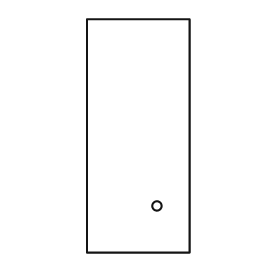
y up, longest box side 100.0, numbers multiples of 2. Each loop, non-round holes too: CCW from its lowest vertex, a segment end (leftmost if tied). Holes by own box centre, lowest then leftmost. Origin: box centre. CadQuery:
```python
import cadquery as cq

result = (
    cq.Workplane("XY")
    .moveTo(-22.0, -50.0)
    .lineTo(22.0, -50.0)
    .lineTo(22.0, 50.0)
    .lineTo(-22.0, 50.0)
    .close()
    .moveTo(8.0, -30.0)
    .circle(2.0)
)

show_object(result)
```